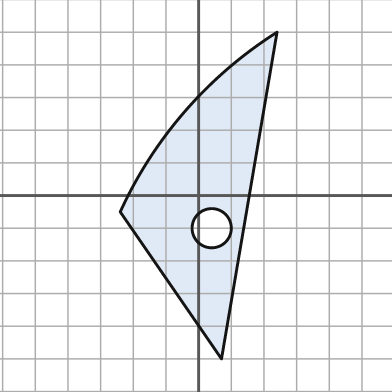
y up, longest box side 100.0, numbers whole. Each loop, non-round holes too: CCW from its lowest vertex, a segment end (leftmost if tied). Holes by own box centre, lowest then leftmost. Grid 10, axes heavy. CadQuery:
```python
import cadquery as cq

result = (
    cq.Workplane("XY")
    .moveTo(7.0, -50.0)
    .lineTo(24.0, 50.0)
    .threePointArc((-4.0, 26.0), (-24.0, -5.0))
    .close()
    .moveTo(4.0, -10.0)
    .circle(6.0)
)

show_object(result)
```